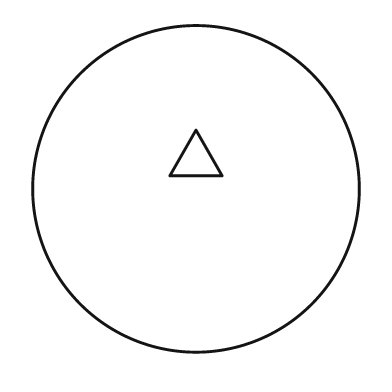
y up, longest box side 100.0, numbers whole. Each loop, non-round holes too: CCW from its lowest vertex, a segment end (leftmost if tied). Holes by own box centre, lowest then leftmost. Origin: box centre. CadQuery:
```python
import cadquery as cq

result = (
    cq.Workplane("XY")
    .moveTo(0.0, 0.0)
    .circle(50.0)
    .moveTo(-8.0, 4.0)
    .lineTo(8.0, 4.0)
    .lineTo(0.0, 18.0)
    .close()
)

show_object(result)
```